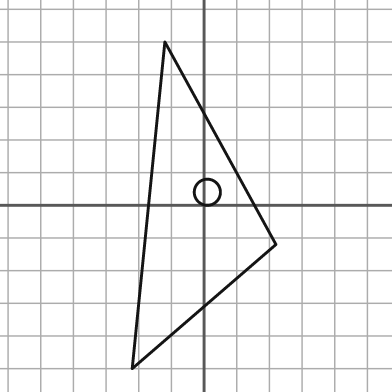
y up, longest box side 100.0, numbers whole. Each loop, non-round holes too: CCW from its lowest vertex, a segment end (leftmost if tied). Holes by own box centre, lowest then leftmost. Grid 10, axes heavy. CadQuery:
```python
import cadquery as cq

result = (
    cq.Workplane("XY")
    .moveTo(-22.0, -50.0)
    .lineTo(22.0, -12.0)
    .lineTo(-12.0, 50.0)
    .close()
    .moveTo(1.0, 4.0)
    .circle(4.0)
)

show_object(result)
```